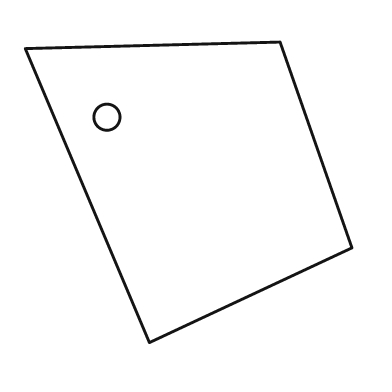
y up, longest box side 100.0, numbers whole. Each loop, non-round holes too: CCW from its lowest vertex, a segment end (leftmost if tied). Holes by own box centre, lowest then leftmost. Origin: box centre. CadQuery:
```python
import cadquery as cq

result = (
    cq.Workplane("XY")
    .moveTo(-12.0, -46.0)
    .lineTo(50.0, -17.0)
    .lineTo(28.0, 46.0)
    .lineTo(-50.0, 44.0)
    .close()
    .moveTo(-25.0, 23.0)
    .circle(4.0)
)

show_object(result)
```